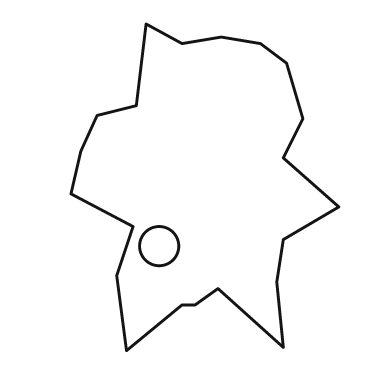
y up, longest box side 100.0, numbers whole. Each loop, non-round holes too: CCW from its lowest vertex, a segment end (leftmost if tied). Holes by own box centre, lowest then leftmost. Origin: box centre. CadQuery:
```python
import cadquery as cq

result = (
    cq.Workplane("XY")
    .moveTo(-24.0, -50.0)
    .lineTo(-7.0, -36.0)
    .lineTo(-3.0, -36.0)
    .lineTo(4.0, -31.0)
    .lineTo(24.0, -49.0)
    .lineTo(22.0, -29.0)
    .lineTo(24.0, -16.0)
    .lineTo(41.0, -6.0)
    .lineTo(24.0, 9.0)
    .lineTo(30.0, 21.0)
    .lineTo(25.0, 38.0)
    .lineTo(17.0, 44.0)
    .lineTo(5.0, 46.0)
    .lineTo(-7.0, 44.0)
    .lineTo(-18.0, 50.0)
    .lineTo(-21.0, 25.0)
    .lineTo(-33.0, 22.0)
    .lineTo(-38.0, 11.0)
    .lineTo(-41.0, -2.0)
    .lineTo(-22.0, -12.0)
    .lineTo(-27.0, -27.0)
    .close()
    .moveTo(-14.0, -18.0)
    .circle(6.0)
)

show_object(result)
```